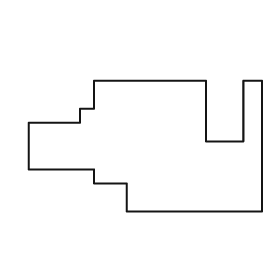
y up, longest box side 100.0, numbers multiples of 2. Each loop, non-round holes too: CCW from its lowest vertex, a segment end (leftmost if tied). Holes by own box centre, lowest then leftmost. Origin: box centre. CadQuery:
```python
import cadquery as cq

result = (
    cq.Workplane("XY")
    .moveTo(-8.0, -28.0)
    .lineTo(50.0, -28.0)
    .lineTo(50.0, 28.0)
    .lineTo(42.0, 28.0)
    .lineTo(42.0, 2.0)
    .lineTo(26.0, 2.0)
    .lineTo(26.0, 28.0)
    .lineTo(-22.0, 28.0)
    .lineTo(-22.0, 16.0)
    .lineTo(-28.0, 16.0)
    .lineTo(-28.0, 10.0)
    .lineTo(-50.0, 10.0)
    .lineTo(-50.0, -10.0)
    .lineTo(-22.0, -10.0)
    .lineTo(-22.0, -16.0)
    .lineTo(-8.0, -16.0)
    .close()
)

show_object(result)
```